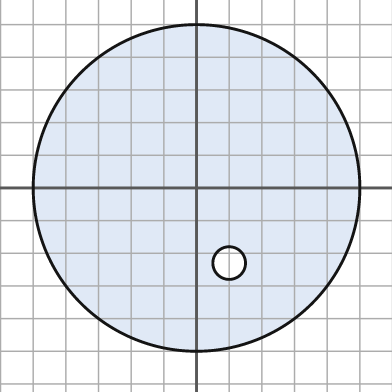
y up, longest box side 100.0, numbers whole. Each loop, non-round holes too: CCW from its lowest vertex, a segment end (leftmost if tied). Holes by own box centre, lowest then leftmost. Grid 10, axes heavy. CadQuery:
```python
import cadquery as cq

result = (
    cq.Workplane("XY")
    .moveTo(0.0, 0.0)
    .circle(50.0)
    .moveTo(10.0, -23.0)
    .circle(5.0)
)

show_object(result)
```